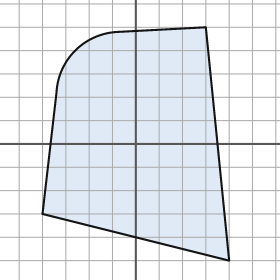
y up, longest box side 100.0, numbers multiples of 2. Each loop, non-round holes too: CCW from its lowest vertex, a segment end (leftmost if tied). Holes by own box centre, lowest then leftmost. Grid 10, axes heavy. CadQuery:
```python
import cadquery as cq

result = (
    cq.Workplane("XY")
    .moveTo(40.0, -50.0)
    .lineTo(30.0, 50.0)
    .lineTo(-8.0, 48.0)
    .threePointArc((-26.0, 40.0), (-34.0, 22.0))
    .lineTo(-40.0, -30.0)
    .close()
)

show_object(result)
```